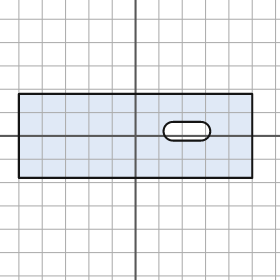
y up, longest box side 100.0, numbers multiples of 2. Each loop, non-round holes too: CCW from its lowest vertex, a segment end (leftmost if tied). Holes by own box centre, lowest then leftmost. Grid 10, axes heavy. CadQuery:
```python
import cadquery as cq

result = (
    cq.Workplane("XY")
    .moveTo(-50.0, -18.0)
    .lineTo(50.0, -18.0)
    .lineTo(50.0, 18.0)
    .lineTo(-50.0, 18.0)
    .close()
    .moveTo(16.0, -2.0)
    .lineTo(28.0, -2.0)
    .threePointArc((32.0, 2.0), (28.0, 6.0))
    .lineTo(16.0, 6.0)
    .threePointArc((12.0, 2.0), (16.0, -2.0))
    .close()
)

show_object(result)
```